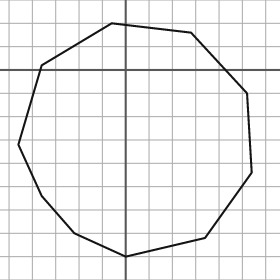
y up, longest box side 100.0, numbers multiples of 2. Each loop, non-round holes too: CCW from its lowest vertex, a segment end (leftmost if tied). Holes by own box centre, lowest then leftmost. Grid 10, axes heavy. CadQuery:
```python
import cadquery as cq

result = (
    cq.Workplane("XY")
    .moveTo(0.0, -80.0)
    .lineTo(34.0, -72.0)
    .lineTo(54.0, -44.0)
    .lineTo(52.0, -10.0)
    .lineTo(28.0, 16.0)
    .lineTo(-6.0, 20.0)
    .lineTo(-36.0, 2.0)
    .lineTo(-46.0, -32.0)
    .lineTo(-36.0, -54.0)
    .lineTo(-22.0, -70.0)
    .close()
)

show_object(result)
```